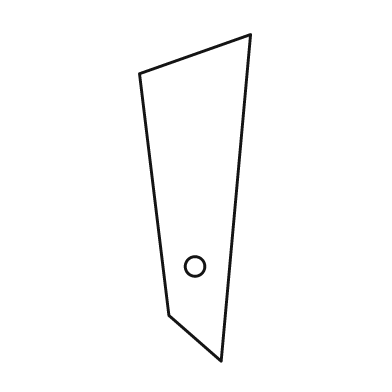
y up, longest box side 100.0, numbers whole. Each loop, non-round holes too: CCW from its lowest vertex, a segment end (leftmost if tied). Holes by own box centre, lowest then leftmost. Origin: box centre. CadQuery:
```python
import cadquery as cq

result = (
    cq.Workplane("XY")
    .moveTo(8.0, -50.0)
    .lineTo(17.0, 50.0)
    .lineTo(-17.0, 38.0)
    .lineTo(-8.0, -36.0)
    .close()
    .moveTo(0.0, -21.0)
    .circle(3.0)
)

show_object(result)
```